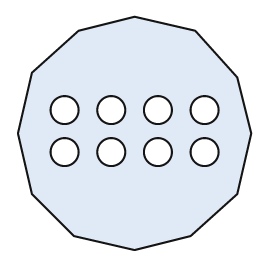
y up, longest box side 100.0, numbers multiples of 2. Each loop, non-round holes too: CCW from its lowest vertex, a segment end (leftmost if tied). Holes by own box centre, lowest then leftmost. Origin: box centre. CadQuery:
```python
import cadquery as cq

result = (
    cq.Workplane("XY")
    .moveTo(0.0, -50.0)
    .lineTo(24.0, -44.0)
    .lineTo(44.0, -26.0)
    .lineTo(50.0, 0.0)
    .lineTo(44.0, 24.0)
    .lineTo(26.0, 44.0)
    .lineTo(0.0, 50.0)
    .lineTo(-24.0, 44.0)
    .lineTo(-44.0, 26.0)
    .lineTo(-50.0, 0.0)
    .lineTo(-44.0, -26.0)
    .lineTo(-26.0, -44.0)
    .close()
    .moveTo(-30.0, -8.0)
    .circle(6.0)
    .moveTo(-10.0, -8.0)
    .circle(6.0)
    .moveTo(10.0, -8.0)
    .circle(6.0)
    .moveTo(30.0, -8.0)
    .circle(6.0)
    .moveTo(-30.0, 10.0)
    .circle(6.0)
    .moveTo(-10.0, 10.0)
    .circle(6.0)
    .moveTo(10.0, 10.0)
    .circle(6.0)
    .moveTo(30.0, 10.0)
    .circle(6.0)
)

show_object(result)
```